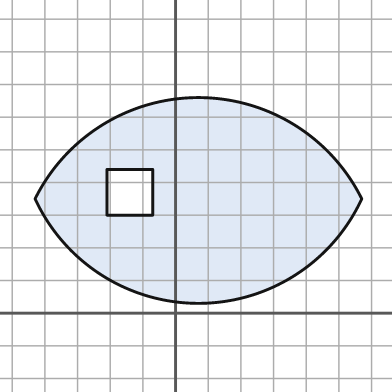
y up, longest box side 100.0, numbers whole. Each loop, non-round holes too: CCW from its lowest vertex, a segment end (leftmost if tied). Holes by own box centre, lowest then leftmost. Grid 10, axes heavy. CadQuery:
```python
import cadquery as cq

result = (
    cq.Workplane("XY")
    .moveTo(-43.0, 35.0)
    .threePointArc((7.0, 3.0), (57.0, 35.0))
    .threePointArc((7.0, 66.0), (-43.0, 35.0))
    .close()
    .moveTo(-21.0, 30.0)
    .lineTo(-7.0, 30.0)
    .lineTo(-7.0, 44.0)
    .lineTo(-21.0, 44.0)
    .close()
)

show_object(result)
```